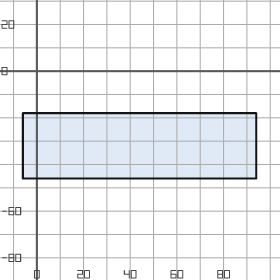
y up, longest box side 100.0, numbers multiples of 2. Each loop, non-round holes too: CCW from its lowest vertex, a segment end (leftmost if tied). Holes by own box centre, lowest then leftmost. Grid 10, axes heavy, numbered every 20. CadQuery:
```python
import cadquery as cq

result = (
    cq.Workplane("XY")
    .moveTo(-6.0, -46.0)
    .lineTo(94.0, -46.0)
    .lineTo(94.0, -18.0)
    .lineTo(-6.0, -18.0)
    .close()
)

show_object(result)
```